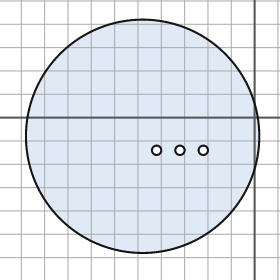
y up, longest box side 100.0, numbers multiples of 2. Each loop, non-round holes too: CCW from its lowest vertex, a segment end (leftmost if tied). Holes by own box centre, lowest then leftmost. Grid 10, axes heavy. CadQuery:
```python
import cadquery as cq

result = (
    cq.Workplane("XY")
    .moveTo(-48.0, -8.0)
    .circle(50.0)
    .moveTo(-42.0, -14.0)
    .circle(2.0)
    .moveTo(-32.0, -14.0)
    .circle(2.0)
    .moveTo(-22.0, -14.0)
    .circle(2.0)
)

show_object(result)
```